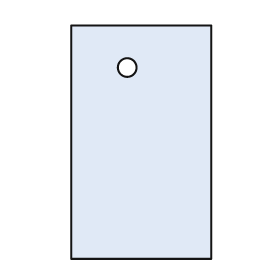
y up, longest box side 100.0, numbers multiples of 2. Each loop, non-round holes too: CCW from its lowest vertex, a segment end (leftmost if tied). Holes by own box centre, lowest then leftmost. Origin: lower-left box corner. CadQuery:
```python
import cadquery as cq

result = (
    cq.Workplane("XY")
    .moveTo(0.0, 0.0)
    .lineTo(60.0, 0.0)
    .lineTo(60.0, 100.0)
    .lineTo(0.0, 100.0)
    .close()
    .moveTo(24.0, 82.0)
    .circle(4.0)
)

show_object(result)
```